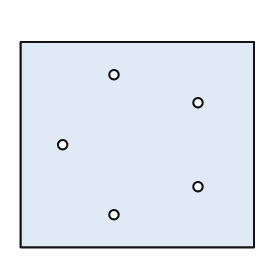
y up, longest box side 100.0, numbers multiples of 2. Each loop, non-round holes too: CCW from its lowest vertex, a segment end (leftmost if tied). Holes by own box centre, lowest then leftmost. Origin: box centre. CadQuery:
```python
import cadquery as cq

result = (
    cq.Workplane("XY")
    .moveTo(-50.0, -44.0)
    .lineTo(50.0, -44.0)
    .lineTo(50.0, 44.0)
    .lineTo(-50.0, 44.0)
    .close()
    .moveTo(-10.0, -30.0)
    .circle(2.0)
    .moveTo(26.0, -18.0)
    .circle(2.0)
    .moveTo(-32.0, 0.0)
    .circle(2.0)
    .moveTo(26.0, 18.0)
    .circle(2.0)
    .moveTo(-10.0, 30.0)
    .circle(2.0)
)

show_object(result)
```